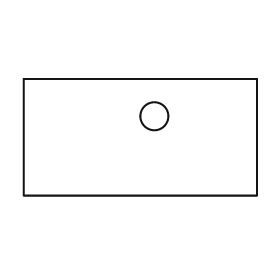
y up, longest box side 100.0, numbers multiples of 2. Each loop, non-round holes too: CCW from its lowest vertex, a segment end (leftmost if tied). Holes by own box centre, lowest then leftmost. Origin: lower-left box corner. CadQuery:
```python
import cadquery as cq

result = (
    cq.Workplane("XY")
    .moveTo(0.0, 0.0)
    .lineTo(100.0, 0.0)
    .lineTo(100.0, 50.0)
    .lineTo(0.0, 50.0)
    .close()
    .moveTo(56.0, 34.0)
    .circle(6.0)
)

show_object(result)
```